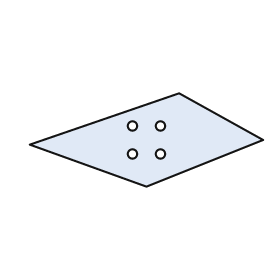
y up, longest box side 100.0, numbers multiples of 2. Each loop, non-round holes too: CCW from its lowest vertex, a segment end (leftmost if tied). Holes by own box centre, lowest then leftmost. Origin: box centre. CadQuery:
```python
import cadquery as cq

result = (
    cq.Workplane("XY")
    .moveTo(0.0, -20.0)
    .lineTo(50.0, 0.0)
    .lineTo(14.0, 20.0)
    .lineTo(-50.0, -2.0)
    .close()
    .moveTo(-6.0, -6.0)
    .circle(2.0)
    .moveTo(6.0, -6.0)
    .circle(2.0)
    .moveTo(-6.0, 6.0)
    .circle(2.0)
    .moveTo(6.0, 6.0)
    .circle(2.0)
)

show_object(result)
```